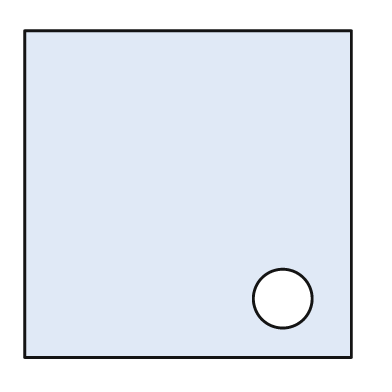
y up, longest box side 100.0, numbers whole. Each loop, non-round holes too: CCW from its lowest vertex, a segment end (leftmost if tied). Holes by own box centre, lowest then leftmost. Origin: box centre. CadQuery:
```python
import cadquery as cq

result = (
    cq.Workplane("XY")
    .moveTo(-50.0, -50.0)
    .lineTo(50.0, -50.0)
    .lineTo(50.0, 50.0)
    .lineTo(-50.0, 50.0)
    .close()
    .moveTo(29.0, -32.0)
    .circle(9.0)
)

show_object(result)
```